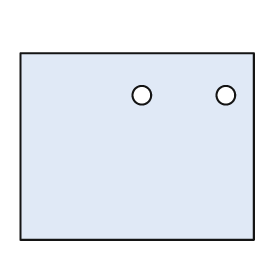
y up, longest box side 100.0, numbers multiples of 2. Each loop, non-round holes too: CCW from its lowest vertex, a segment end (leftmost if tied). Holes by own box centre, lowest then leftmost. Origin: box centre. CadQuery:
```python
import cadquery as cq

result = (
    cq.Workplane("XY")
    .moveTo(-50.0, -40.0)
    .lineTo(50.0, -40.0)
    .lineTo(50.0, 40.0)
    .lineTo(-50.0, 40.0)
    .close()
    .moveTo(2.0, 22.0)
    .circle(4.0)
    .moveTo(38.0, 22.0)
    .circle(4.0)
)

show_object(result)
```